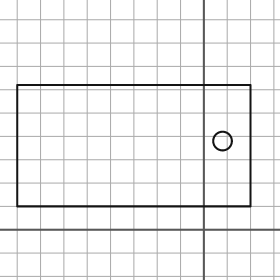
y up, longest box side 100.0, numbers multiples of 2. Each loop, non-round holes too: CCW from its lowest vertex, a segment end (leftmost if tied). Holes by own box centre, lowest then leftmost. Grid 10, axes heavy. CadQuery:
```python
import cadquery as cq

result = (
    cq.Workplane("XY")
    .moveTo(-80.0, 10.0)
    .lineTo(20.0, 10.0)
    .lineTo(20.0, 62.0)
    .lineTo(-80.0, 62.0)
    .close()
    .moveTo(8.0, 38.0)
    .circle(4.0)
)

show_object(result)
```